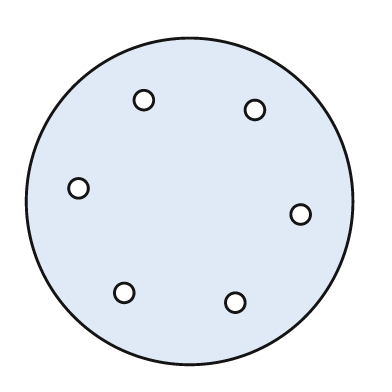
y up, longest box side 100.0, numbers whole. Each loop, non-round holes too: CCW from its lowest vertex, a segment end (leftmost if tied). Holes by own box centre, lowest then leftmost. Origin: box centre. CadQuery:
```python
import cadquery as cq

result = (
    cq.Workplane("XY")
    .moveTo(0.0, 0.0)
    .circle(50.0)
    .moveTo(14.0, -31.0)
    .circle(3.0)
    .moveTo(-20.0, -28.0)
    .circle(3.0)
    .moveTo(34.0, -4.0)
    .circle(3.0)
    .moveTo(-34.0, 4.0)
    .circle(3.0)
    .moveTo(20.0, 28.0)
    .circle(3.0)
    .moveTo(-14.0, 31.0)
    .circle(3.0)
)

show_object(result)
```